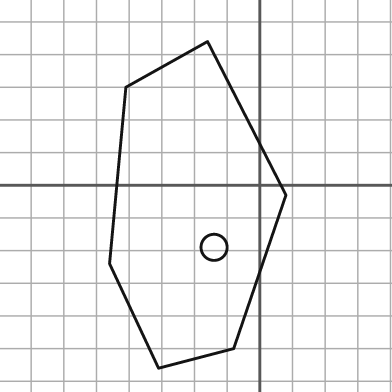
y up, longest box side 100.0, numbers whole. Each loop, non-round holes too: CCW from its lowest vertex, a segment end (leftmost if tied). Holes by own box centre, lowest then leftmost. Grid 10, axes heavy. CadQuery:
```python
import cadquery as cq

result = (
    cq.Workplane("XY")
    .moveTo(-31.0, -56.0)
    .lineTo(-8.0, -50.0)
    .lineTo(8.0, -3.0)
    .lineTo(-16.0, 44.0)
    .lineTo(-41.0, 30.0)
    .lineTo(-46.0, -24.0)
    .close()
    .moveTo(-14.0, -19.0)
    .circle(4.0)
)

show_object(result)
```